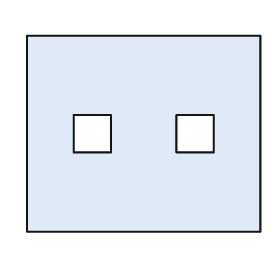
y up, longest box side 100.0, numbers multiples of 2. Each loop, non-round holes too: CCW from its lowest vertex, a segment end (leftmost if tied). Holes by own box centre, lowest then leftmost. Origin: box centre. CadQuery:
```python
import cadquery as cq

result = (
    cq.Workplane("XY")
    .moveTo(-50.0, -42.0)
    .lineTo(50.0, -42.0)
    .lineTo(50.0, 42.0)
    .lineTo(-50.0, 42.0)
    .close()
    .moveTo(-30.0, -8.0)
    .lineTo(-14.0, -8.0)
    .lineTo(-14.0, 8.0)
    .lineTo(-30.0, 8.0)
    .close()
    .moveTo(14.0, -8.0)
    .lineTo(30.0, -8.0)
    .lineTo(30.0, 8.0)
    .lineTo(14.0, 8.0)
    .close()
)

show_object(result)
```